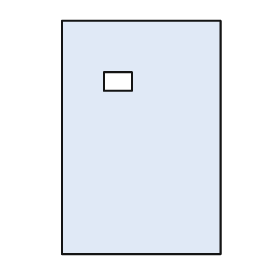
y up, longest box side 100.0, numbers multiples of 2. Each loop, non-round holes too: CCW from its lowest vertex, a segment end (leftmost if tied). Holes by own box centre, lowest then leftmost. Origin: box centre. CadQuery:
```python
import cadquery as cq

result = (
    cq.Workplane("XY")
    .moveTo(-34.0, -50.0)
    .lineTo(34.0, -50.0)
    .lineTo(34.0, 50.0)
    .lineTo(-34.0, 50.0)
    .close()
    .moveTo(-16.0, 20.0)
    .lineTo(-4.0, 20.0)
    .lineTo(-4.0, 28.0)
    .lineTo(-16.0, 28.0)
    .close()
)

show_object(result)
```